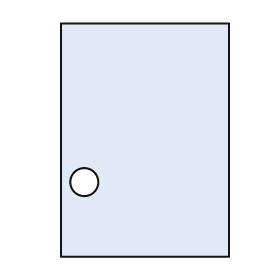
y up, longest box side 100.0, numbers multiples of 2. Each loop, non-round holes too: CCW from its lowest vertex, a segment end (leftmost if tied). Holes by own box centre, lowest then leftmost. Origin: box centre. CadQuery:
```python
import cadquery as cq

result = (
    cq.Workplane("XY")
    .moveTo(-36.0, -50.0)
    .lineTo(36.0, -50.0)
    .lineTo(36.0, 50.0)
    .lineTo(-36.0, 50.0)
    .close()
    .moveTo(-26.0, -18.0)
    .circle(6.0)
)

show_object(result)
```